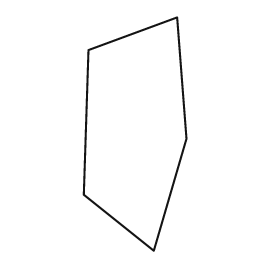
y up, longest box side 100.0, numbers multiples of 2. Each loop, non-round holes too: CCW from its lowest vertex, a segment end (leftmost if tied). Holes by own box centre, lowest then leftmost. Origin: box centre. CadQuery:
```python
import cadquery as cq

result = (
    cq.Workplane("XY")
    .moveTo(8.0, -50.0)
    .lineTo(22.0, -2.0)
    .lineTo(18.0, 50.0)
    .lineTo(-20.0, 36.0)
    .lineTo(-22.0, -26.0)
    .close()
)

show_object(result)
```